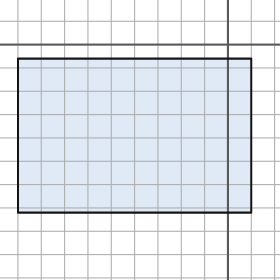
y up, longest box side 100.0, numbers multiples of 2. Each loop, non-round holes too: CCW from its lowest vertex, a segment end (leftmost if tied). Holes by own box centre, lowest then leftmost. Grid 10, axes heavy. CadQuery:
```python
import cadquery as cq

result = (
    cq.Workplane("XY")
    .moveTo(-90.0, -72.0)
    .lineTo(10.0, -72.0)
    .lineTo(10.0, -6.0)
    .lineTo(-90.0, -6.0)
    .close()
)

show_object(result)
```